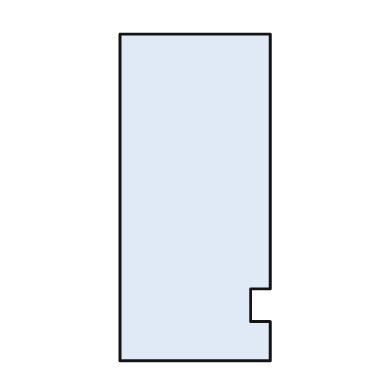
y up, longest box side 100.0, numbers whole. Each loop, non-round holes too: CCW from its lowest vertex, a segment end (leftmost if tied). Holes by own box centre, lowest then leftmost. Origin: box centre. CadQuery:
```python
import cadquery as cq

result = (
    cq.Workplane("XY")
    .moveTo(-23.0, -50.0)
    .lineTo(23.0, -50.0)
    .lineTo(23.0, -38.0)
    .lineTo(17.0, -38.0)
    .lineTo(17.0, -28.0)
    .lineTo(23.0, -28.0)
    .lineTo(23.0, 50.0)
    .lineTo(-23.0, 50.0)
    .close()
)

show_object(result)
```